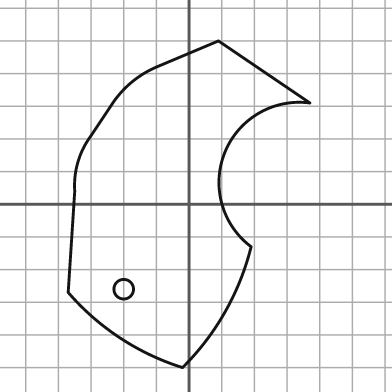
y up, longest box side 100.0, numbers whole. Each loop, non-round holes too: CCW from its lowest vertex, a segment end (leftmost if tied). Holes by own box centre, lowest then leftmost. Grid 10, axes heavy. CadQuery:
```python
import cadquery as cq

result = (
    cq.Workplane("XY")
    .moveTo(-2.0, -50.0)
    .threePointArc((11.0, -33.0), (19.0, -13.0))
    .threePointArc((11.0, 16.0), (37.0, 31.0))
    .lineTo(9.0, 50.0)
    .lineTo(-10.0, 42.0)
    .threePointArc((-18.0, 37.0), (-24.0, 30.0))
    .lineTo(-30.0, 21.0)
    .threePointArc((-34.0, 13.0), (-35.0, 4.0))
    .lineTo(-37.0, -27.0)
    .threePointArc((-21.0, -41.0), (-2.0, -50.0))
    .close()
    .moveTo(-20.0, -26.0)
    .circle(3.0)
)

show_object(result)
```